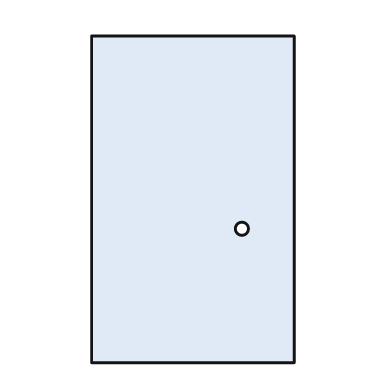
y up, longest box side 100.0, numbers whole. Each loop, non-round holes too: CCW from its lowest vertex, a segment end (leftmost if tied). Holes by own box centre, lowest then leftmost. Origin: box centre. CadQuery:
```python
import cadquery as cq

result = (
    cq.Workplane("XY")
    .moveTo(-31.0, -50.0)
    .lineTo(31.0, -50.0)
    .lineTo(31.0, 50.0)
    .lineTo(-31.0, 50.0)
    .close()
    .moveTo(15.0, -9.0)
    .circle(2.0)
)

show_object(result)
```